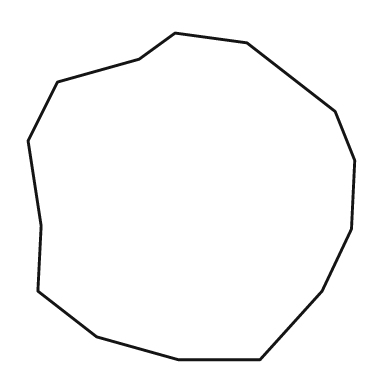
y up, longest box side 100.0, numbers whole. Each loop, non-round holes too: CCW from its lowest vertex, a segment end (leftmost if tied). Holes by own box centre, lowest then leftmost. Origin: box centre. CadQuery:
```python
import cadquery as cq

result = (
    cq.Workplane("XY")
    .moveTo(-4.0, -50.0)
    .lineTo(21.0, -50.0)
    .lineTo(40.0, -29.0)
    .lineTo(49.0, -10.0)
    .lineTo(50.0, 11.0)
    .lineTo(44.0, 26.0)
    .lineTo(17.0, 47.0)
    .lineTo(-5.0, 50.0)
    .lineTo(-16.0, 42.0)
    .lineTo(-41.0, 35.0)
    .lineTo(-50.0, 17.0)
    .lineTo(-46.0, -9.0)
    .lineTo(-47.0, -29.0)
    .lineTo(-29.0, -43.0)
    .close()
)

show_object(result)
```